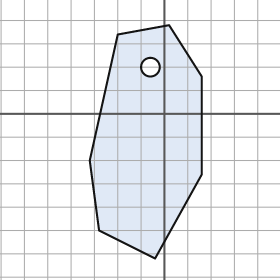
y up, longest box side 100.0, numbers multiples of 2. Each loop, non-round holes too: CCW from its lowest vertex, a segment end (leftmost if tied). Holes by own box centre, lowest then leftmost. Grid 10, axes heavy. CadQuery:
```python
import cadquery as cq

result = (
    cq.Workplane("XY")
    .moveTo(-4.0, -62.0)
    .lineTo(16.0, -26.0)
    .lineTo(16.0, 16.0)
    .lineTo(2.0, 38.0)
    .lineTo(-20.0, 34.0)
    .lineTo(-32.0, -20.0)
    .lineTo(-28.0, -50.0)
    .close()
    .moveTo(-6.0, 20.0)
    .circle(4.0)
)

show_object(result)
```